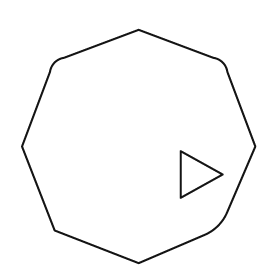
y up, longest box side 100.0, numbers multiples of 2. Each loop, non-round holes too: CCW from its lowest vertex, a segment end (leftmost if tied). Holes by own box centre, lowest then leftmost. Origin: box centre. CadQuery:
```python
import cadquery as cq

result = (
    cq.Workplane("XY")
    .moveTo(0.0, -50.0)
    .lineTo(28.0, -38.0)
    .threePointArc((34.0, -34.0), (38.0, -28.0))
    .lineTo(50.0, 0.0)
    .lineTo(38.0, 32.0)
    .threePointArc((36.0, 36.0), (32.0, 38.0))
    .lineTo(0.0, 50.0)
    .lineTo(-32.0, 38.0)
    .threePointArc((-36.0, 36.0), (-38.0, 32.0))
    .lineTo(-50.0, 0.0)
    .lineTo(-36.0, -36.0)
    .close()
    .moveTo(18.0, -22.0)
    .lineTo(36.0, -12.0)
    .lineTo(18.0, -2.0)
    .close()
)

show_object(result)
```